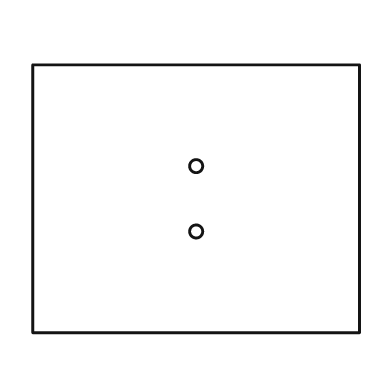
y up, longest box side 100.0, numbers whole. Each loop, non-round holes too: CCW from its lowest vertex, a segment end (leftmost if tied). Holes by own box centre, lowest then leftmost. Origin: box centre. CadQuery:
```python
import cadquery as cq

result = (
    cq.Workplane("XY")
    .moveTo(-50.0, -41.0)
    .lineTo(50.0, -41.0)
    .lineTo(50.0, 41.0)
    .lineTo(-50.0, 41.0)
    .close()
    .moveTo(0.0, -10.0)
    .circle(2.0)
    .moveTo(0.0, 10.0)
    .circle(2.0)
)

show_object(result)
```